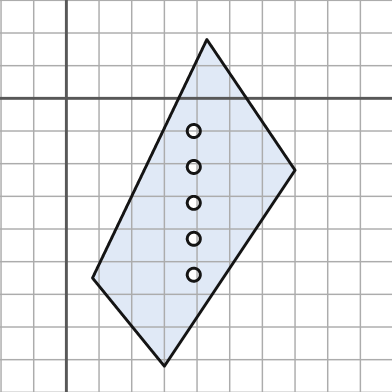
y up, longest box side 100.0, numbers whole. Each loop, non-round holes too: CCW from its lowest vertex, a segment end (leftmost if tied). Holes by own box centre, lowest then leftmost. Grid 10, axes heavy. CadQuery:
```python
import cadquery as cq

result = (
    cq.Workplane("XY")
    .moveTo(30.0, -82.0)
    .lineTo(70.0, -22.0)
    .lineTo(43.0, 18.0)
    .lineTo(8.0, -55.0)
    .close()
    .moveTo(39.0, -54.0)
    .circle(2.0)
    .moveTo(39.0, -43.0)
    .circle(2.0)
    .moveTo(39.0, -32.0)
    .circle(2.0)
    .moveTo(39.0, -21.0)
    .circle(2.0)
    .moveTo(39.0, -10.0)
    .circle(2.0)
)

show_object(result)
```